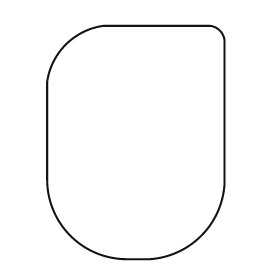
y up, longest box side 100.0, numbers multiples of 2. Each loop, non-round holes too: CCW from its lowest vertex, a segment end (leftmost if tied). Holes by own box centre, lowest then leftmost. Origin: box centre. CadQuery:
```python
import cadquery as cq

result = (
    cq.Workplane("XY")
    .moveTo(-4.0, -50.0)
    .lineTo(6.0, -50.0)
    .threePointArc((28.0, -40.0), (38.0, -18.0))
    .lineTo(38.0, 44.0)
    .threePointArc((36.0, 48.0), (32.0, 50.0))
    .lineTo(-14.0, 50.0)
    .threePointArc((-30.0, 42.0), (-38.0, 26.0))
    .lineTo(-38.0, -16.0)
    .threePointArc((-28.0, -40.0), (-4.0, -50.0))
    .close()
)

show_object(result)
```